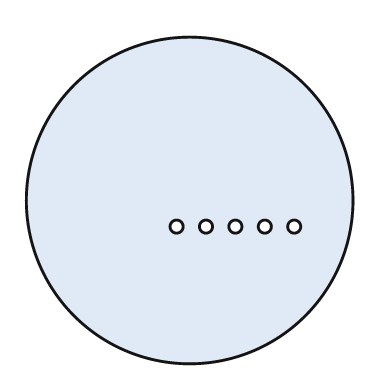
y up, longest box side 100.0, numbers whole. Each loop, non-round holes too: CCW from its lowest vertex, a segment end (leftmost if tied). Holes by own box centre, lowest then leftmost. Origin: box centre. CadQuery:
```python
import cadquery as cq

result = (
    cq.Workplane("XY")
    .moveTo(0.0, 0.0)
    .circle(50.0)
    .moveTo(-4.0, -8.0)
    .circle(2.0)
    .moveTo(5.0, -8.0)
    .circle(2.0)
    .moveTo(14.0, -8.0)
    .circle(2.0)
    .moveTo(23.0, -8.0)
    .circle(2.0)
    .moveTo(32.0, -8.0)
    .circle(2.0)
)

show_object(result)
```